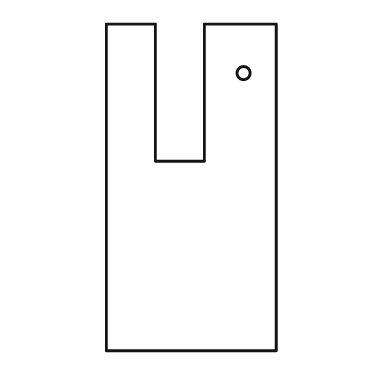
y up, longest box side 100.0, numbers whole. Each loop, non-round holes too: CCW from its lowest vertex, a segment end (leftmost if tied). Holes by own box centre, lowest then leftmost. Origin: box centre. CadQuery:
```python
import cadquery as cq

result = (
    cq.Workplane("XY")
    .moveTo(-26.0, -50.0)
    .lineTo(26.0, -50.0)
    .lineTo(26.0, 50.0)
    .lineTo(4.0, 50.0)
    .lineTo(4.0, 8.0)
    .lineTo(-11.0, 8.0)
    .lineTo(-11.0, 50.0)
    .lineTo(-26.0, 50.0)
    .close()
    .moveTo(16.0, 35.0)
    .circle(2.0)
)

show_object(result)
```